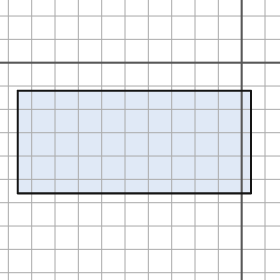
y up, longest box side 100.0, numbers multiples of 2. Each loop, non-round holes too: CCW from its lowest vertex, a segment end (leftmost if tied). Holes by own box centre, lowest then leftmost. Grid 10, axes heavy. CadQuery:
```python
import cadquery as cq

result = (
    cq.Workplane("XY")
    .moveTo(-96.0, -56.0)
    .lineTo(4.0, -56.0)
    .lineTo(4.0, -12.0)
    .lineTo(-96.0, -12.0)
    .close()
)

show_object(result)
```